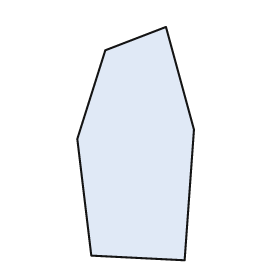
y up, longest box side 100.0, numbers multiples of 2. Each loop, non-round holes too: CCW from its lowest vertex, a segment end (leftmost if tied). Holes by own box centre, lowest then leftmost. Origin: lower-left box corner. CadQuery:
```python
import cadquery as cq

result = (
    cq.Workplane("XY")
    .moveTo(46.0, 0.0)
    .lineTo(50.0, 56.0)
    .lineTo(38.0, 100.0)
    .lineTo(12.0, 90.0)
    .lineTo(0.0, 52.0)
    .lineTo(6.0, 2.0)
    .close()
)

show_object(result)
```